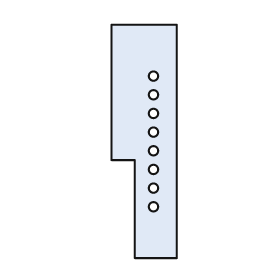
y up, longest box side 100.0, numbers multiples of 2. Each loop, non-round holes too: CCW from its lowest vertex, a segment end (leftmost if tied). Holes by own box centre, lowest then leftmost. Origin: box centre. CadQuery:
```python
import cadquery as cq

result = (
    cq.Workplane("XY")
    .moveTo(-4.0, -50.0)
    .lineTo(14.0, -50.0)
    .lineTo(14.0, 50.0)
    .lineTo(-14.0, 50.0)
    .lineTo(-14.0, -8.0)
    .lineTo(-4.0, -8.0)
    .close()
    .moveTo(4.0, -28.0)
    .circle(2.0)
    .moveTo(4.0, -20.0)
    .circle(2.0)
    .moveTo(4.0, -12.0)
    .circle(2.0)
    .moveTo(4.0, -4.0)
    .circle(2.0)
    .moveTo(4.0, 4.0)
    .circle(2.0)
    .moveTo(4.0, 12.0)
    .circle(2.0)
    .moveTo(4.0, 20.0)
    .circle(2.0)
    .moveTo(4.0, 28.0)
    .circle(2.0)
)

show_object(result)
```